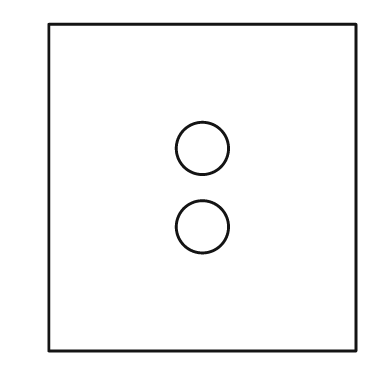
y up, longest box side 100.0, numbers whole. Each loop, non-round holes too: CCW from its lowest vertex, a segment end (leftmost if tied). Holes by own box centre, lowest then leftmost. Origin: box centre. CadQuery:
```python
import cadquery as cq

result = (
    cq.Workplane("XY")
    .moveTo(-47.0, -50.0)
    .lineTo(47.0, -50.0)
    .lineTo(47.0, 50.0)
    .lineTo(-47.0, 50.0)
    .close()
    .moveTo(0.0, -12.0)
    .circle(8.0)
    .moveTo(0.0, 12.0)
    .circle(8.0)
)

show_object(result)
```